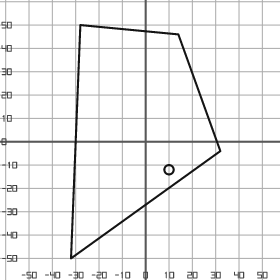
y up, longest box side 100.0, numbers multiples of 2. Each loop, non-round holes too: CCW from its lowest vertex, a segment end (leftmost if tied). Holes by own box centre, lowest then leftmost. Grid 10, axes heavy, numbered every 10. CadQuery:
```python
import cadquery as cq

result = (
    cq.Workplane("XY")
    .moveTo(-32.0, -50.0)
    .lineTo(32.0, -4.0)
    .lineTo(14.0, 46.0)
    .lineTo(-28.0, 50.0)
    .close()
    .moveTo(10.0, -12.0)
    .circle(2.0)
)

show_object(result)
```